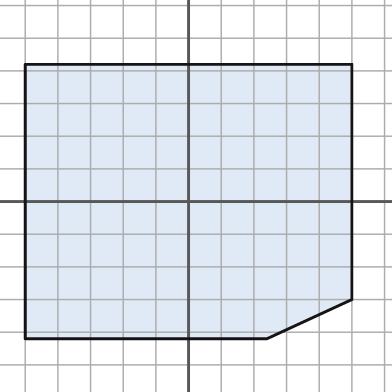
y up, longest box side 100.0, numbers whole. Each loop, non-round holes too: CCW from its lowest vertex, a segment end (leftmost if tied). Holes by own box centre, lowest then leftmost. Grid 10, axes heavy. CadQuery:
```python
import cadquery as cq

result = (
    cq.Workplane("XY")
    .moveTo(-50.0, -42.0)
    .lineTo(24.0, -42.0)
    .lineTo(50.0, -30.0)
    .lineTo(50.0, 42.0)
    .lineTo(-50.0, 42.0)
    .close()
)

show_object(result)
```